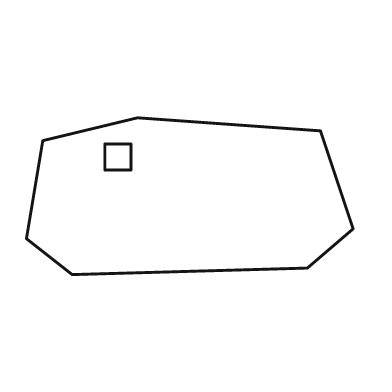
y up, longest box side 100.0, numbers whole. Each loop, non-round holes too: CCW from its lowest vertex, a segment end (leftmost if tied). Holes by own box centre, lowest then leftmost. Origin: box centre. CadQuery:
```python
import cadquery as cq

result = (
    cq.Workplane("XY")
    .moveTo(-36.0, -24.0)
    .lineTo(36.0, -22.0)
    .lineTo(50.0, -10.0)
    .lineTo(40.0, 20.0)
    .lineTo(-16.0, 24.0)
    .lineTo(-45.0, 17.0)
    .lineTo(-50.0, -13.0)
    .close()
    .moveTo(-26.0, 8.0)
    .lineTo(-18.0, 8.0)
    .lineTo(-18.0, 16.0)
    .lineTo(-26.0, 16.0)
    .close()
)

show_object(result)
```